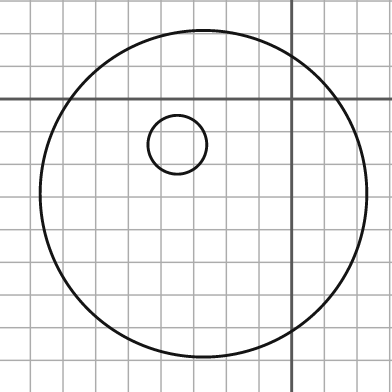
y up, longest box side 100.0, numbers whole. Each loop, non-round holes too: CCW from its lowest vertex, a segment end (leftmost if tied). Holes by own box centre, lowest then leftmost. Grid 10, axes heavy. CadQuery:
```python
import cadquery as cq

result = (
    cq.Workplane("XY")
    .moveTo(-27.0, -29.0)
    .circle(50.0)
    .moveTo(-35.0, -14.0)
    .circle(9.0)
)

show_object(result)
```